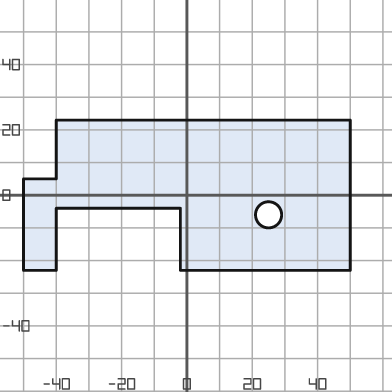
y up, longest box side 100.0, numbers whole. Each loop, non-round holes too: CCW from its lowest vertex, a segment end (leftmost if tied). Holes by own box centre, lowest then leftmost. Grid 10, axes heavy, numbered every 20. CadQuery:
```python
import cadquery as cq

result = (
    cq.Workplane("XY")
    .moveTo(-50.0, -23.0)
    .lineTo(-40.0, -23.0)
    .lineTo(-40.0, -4.0)
    .lineTo(-2.0, -4.0)
    .lineTo(-2.0, -23.0)
    .lineTo(50.0, -23.0)
    .lineTo(50.0, 23.0)
    .lineTo(-40.0, 23.0)
    .lineTo(-40.0, 5.0)
    .lineTo(-50.0, 5.0)
    .close()
    .moveTo(25.0, -6.0)
    .circle(4.0)
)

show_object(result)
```